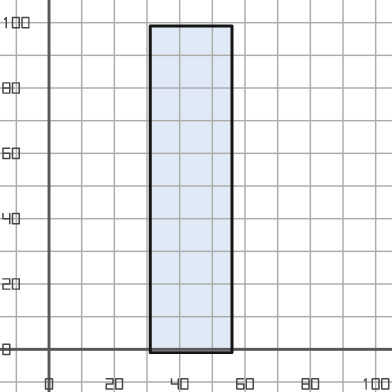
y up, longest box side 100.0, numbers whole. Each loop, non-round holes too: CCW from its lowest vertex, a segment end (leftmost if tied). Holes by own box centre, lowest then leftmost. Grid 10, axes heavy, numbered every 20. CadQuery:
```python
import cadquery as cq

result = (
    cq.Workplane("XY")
    .moveTo(31.0, -1.0)
    .lineTo(56.0, -1.0)
    .lineTo(56.0, 99.0)
    .lineTo(31.0, 99.0)
    .close()
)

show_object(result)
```